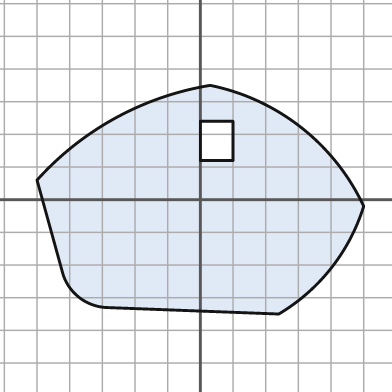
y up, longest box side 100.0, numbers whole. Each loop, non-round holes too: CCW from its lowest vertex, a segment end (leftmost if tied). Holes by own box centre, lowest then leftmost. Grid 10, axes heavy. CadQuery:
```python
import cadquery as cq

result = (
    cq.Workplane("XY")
    .moveTo(24.0, -35.0)
    .threePointArc((40.0, -21.0), (50.0, -2.0))
    .threePointArc((31.0, 22.0), (3.0, 35.0))
    .threePointArc((-26.0, 25.0), (-50.0, 6.0))
    .lineTo(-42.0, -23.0)
    .threePointArc((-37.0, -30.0), (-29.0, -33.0))
    .close()
    .moveTo(0.0, 12.0)
    .lineTo(10.0, 12.0)
    .lineTo(10.0, 24.0)
    .lineTo(0.0, 24.0)
    .close()
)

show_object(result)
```